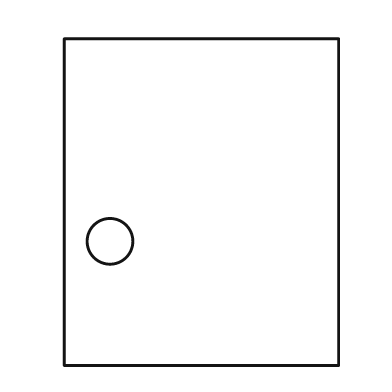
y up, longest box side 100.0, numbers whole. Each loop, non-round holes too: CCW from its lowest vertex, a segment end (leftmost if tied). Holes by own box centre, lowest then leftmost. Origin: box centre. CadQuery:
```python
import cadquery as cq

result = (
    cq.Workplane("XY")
    .moveTo(-42.0, -50.0)
    .lineTo(42.0, -50.0)
    .lineTo(42.0, 50.0)
    .lineTo(-42.0, 50.0)
    .close()
    .moveTo(-28.0, -12.0)
    .circle(7.0)
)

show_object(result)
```